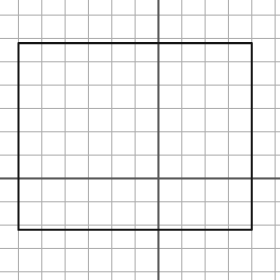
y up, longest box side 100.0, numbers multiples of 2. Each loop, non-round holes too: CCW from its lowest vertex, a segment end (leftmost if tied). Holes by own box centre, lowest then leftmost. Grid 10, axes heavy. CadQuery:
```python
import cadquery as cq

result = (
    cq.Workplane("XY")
    .moveTo(-60.0, -22.0)
    .lineTo(40.0, -22.0)
    .lineTo(40.0, 58.0)
    .lineTo(-60.0, 58.0)
    .close()
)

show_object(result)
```